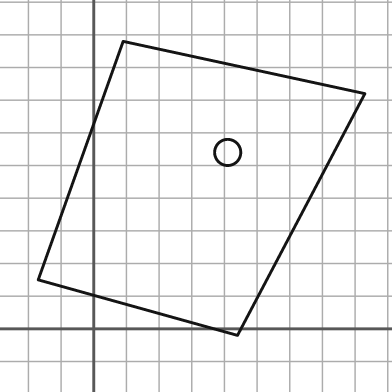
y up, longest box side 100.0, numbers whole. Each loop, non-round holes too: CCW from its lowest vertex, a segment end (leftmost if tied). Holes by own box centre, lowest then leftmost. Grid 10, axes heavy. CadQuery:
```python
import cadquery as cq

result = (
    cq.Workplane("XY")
    .moveTo(44.0, -2.0)
    .lineTo(83.0, 72.0)
    .lineTo(9.0, 88.0)
    .lineTo(-17.0, 15.0)
    .close()
    .moveTo(41.0, 54.0)
    .circle(4.0)
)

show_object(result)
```